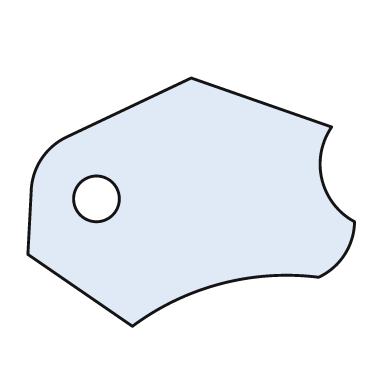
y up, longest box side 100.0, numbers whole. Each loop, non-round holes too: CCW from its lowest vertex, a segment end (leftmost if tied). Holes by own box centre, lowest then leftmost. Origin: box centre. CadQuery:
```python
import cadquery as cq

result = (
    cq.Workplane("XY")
    .moveTo(-18.0, -38.0)
    .threePointArc((9.0, -25.0), (39.0, -23.0))
    .threePointArc((47.0, -16.0), (50.0, -6.0))
    .threePointArc((40.0, 7.0), (43.0, 23.0))
    .lineTo(0.0, 38.0)
    .lineTo(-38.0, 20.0)
    .threePointArc((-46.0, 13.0), (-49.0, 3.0))
    .lineTo(-50.0, -16.0)
    .close()
    .moveTo(-29.0, 1.0)
    .circle(7.0)
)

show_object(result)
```